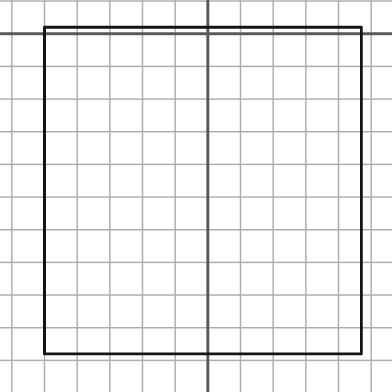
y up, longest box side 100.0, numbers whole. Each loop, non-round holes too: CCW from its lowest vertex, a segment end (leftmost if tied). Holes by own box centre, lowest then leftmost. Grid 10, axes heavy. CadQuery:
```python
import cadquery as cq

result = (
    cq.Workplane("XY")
    .moveTo(-50.0, -98.0)
    .lineTo(47.0, -98.0)
    .lineTo(47.0, 2.0)
    .lineTo(-50.0, 2.0)
    .close()
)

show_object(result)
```